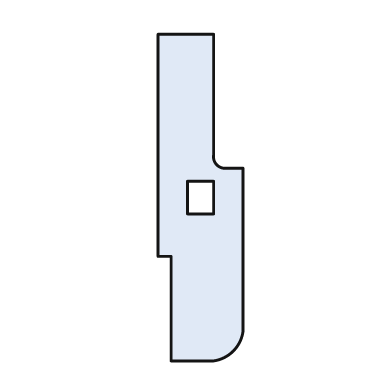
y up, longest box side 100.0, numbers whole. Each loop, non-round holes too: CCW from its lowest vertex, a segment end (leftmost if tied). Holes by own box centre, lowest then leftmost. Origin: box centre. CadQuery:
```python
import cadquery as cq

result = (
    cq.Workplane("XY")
    .moveTo(-9.0, -50.0)
    .lineTo(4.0, -50.0)
    .threePointArc((10.0, -47.0), (13.0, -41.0))
    .lineTo(13.0, 9.0)
    .lineTo(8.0, 9.0)
    .threePointArc((5.0, 10.0), (4.0, 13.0))
    .lineTo(4.0, 50.0)
    .lineTo(-13.0, 50.0)
    .lineTo(-13.0, -18.0)
    .lineTo(-9.0, -18.0)
    .close()
    .moveTo(-4.0, -5.0)
    .lineTo(4.0, -5.0)
    .lineTo(4.0, 5.0)
    .lineTo(-4.0, 5.0)
    .close()
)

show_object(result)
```